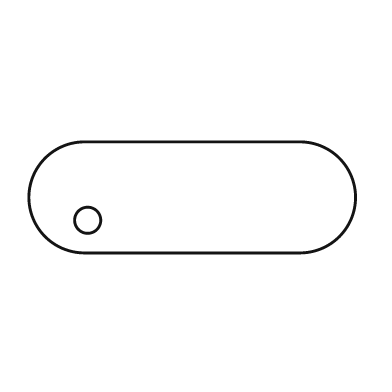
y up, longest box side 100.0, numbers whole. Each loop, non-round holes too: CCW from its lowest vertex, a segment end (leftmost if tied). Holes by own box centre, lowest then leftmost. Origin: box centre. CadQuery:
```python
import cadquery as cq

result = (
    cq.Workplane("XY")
    .moveTo(-33.0, -17.0)
    .lineTo(33.0, -17.0)
    .threePointArc((50.0, 0.0), (33.0, 17.0))
    .lineTo(-33.0, 17.0)
    .threePointArc((-50.0, 0.0), (-33.0, -17.0))
    .close()
    .moveTo(-32.0, -7.0)
    .circle(4.0)
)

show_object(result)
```